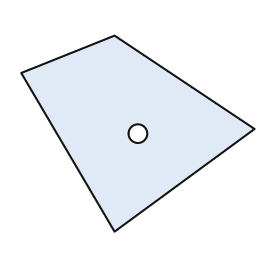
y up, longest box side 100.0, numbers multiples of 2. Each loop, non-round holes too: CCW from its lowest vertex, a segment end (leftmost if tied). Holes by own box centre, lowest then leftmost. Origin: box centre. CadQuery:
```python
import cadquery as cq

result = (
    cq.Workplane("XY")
    .moveTo(-10.0, -42.0)
    .lineTo(50.0, 2.0)
    .lineTo(-10.0, 42.0)
    .lineTo(-50.0, 26.0)
    .close()
    .moveTo(0.0, 0.0)
    .circle(4.0)
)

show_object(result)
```